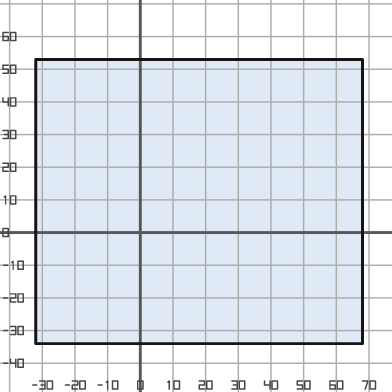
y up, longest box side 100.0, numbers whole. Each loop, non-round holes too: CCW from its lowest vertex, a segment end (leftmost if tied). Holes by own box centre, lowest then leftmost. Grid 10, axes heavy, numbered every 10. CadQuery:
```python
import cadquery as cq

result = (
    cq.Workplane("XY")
    .moveTo(-32.0, -34.0)
    .lineTo(68.0, -34.0)
    .lineTo(68.0, 53.0)
    .lineTo(-32.0, 53.0)
    .close()
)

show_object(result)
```